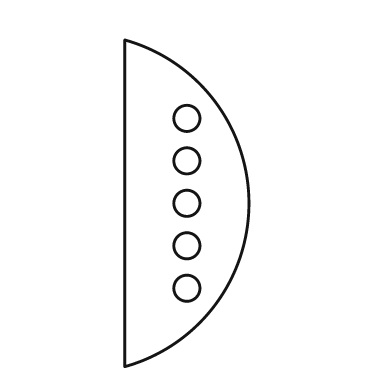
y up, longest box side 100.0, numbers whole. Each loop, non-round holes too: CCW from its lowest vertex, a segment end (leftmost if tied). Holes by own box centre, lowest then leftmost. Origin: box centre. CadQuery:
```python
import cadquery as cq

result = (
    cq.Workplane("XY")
    .moveTo(-19.0, -50.0)
    .threePointArc((19.0, 0.0), (-19.0, 50.0))
    .close()
    .moveTo(0.0, -26.0)
    .circle(4.0)
    .moveTo(0.0, -13.0)
    .circle(4.0)
    .moveTo(0.0, 0.0)
    .circle(4.0)
    .moveTo(0.0, 13.0)
    .circle(4.0)
    .moveTo(0.0, 26.0)
    .circle(4.0)
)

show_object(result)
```